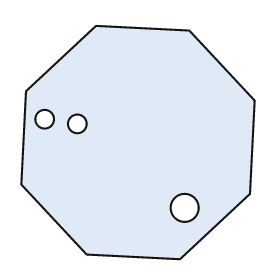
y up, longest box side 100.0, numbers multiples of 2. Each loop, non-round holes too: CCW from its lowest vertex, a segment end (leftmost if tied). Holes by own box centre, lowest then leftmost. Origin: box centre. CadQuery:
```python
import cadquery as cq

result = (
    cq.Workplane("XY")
    .moveTo(18.0, -50.0)
    .lineTo(48.0, -22.0)
    .lineTo(50.0, 18.0)
    .lineTo(22.0, 48.0)
    .lineTo(-18.0, 50.0)
    .lineTo(-48.0, 22.0)
    .lineTo(-50.0, -18.0)
    .lineTo(-22.0, -48.0)
    .close()
    .moveTo(20.0, -28.0)
    .circle(6.0)
    .moveTo(-26.0, 8.0)
    .circle(4.0)
    .moveTo(-40.0, 10.0)
    .circle(4.0)
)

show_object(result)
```